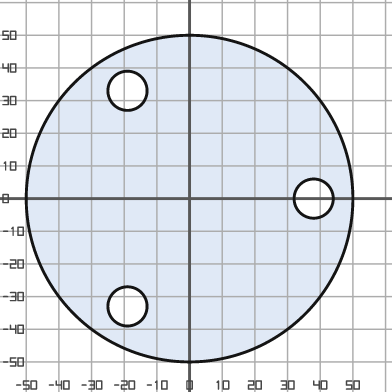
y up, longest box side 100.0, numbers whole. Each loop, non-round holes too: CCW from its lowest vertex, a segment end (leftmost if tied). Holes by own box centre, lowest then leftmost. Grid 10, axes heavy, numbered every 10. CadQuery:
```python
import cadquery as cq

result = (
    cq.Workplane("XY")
    .moveTo(0.0, 0.0)
    .circle(50.0)
    .moveTo(-19.0, -33.0)
    .circle(6.0)
    .moveTo(38.0, 0.0)
    .circle(6.0)
    .moveTo(-19.0, 33.0)
    .circle(6.0)
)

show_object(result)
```